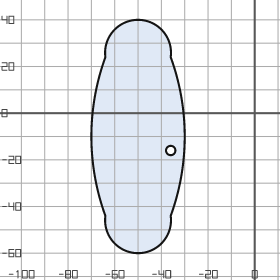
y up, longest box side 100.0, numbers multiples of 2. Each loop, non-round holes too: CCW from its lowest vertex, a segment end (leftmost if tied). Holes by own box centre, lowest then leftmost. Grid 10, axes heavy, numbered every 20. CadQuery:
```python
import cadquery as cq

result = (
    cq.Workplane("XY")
    .moveTo(-64.0, -44.0)
    .threePointArc((-50.0, -60.0), (-36.0, -44.0))
    .threePointArc((-30.0, -10.0), (-36.0, 24.0))
    .threePointArc((-50.0, 40.0), (-64.0, 24.0))
    .threePointArc((-70.0, -10.0), (-64.0, -44.0))
    .close()
    .moveTo(-36.0, -16.0)
    .circle(2.0)
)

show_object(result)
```